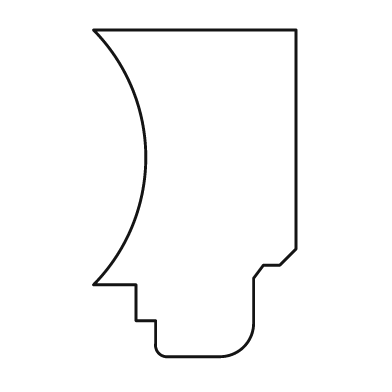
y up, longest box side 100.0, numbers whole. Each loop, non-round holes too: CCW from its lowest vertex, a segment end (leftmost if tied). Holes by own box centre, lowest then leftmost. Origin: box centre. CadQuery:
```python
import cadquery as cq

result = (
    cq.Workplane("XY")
    .moveTo(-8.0, -50.0)
    .lineTo(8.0, -50.0)
    .threePointArc((15.0, -47.0), (18.0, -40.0))
    .lineTo(18.0, -26.0)
    .lineTo(21.0, -22.0)
    .lineTo(26.0, -22.0)
    .lineTo(31.0, -17.0)
    .lineTo(31.0, 50.0)
    .lineTo(-31.0, 50.0)
    .threePointArc((-15.0, 11.0), (-31.0, -28.0))
    .lineTo(-18.0, -28.0)
    .lineTo(-18.0, -39.0)
    .lineTo(-12.0, -39.0)
    .lineTo(-12.0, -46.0)
    .threePointArc((-11.0, -49.0), (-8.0, -50.0))
    .close()
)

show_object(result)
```